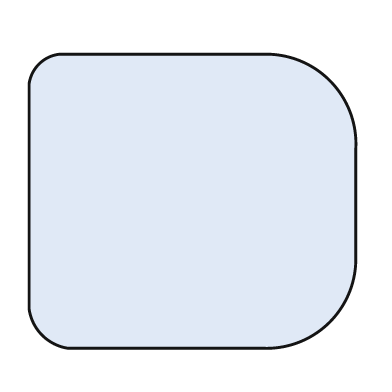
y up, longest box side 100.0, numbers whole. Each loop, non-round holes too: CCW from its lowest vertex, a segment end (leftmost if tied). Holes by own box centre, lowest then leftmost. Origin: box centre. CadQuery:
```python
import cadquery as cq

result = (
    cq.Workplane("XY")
    .moveTo(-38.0, -45.0)
    .lineTo(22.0, -45.0)
    .threePointArc((42.0, -37.0), (50.0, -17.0))
    .lineTo(50.0, 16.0)
    .threePointArc((42.0, 37.0), (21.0, 45.0))
    .lineTo(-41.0, 45.0)
    .threePointArc((-47.0, 42.0), (-50.0, 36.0))
    .lineTo(-50.0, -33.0)
    .threePointArc((-46.0, -41.0), (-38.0, -45.0))
    .close()
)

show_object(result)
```